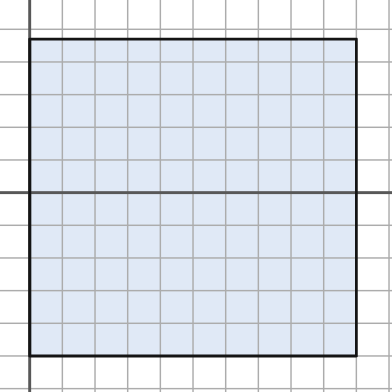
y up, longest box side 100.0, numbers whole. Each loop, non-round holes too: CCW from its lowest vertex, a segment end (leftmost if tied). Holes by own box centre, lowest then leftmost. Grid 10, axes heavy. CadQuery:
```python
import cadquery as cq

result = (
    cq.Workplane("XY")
    .moveTo(0.0, -50.0)
    .lineTo(100.0, -50.0)
    .lineTo(100.0, 47.0)
    .lineTo(0.0, 47.0)
    .close()
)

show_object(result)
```